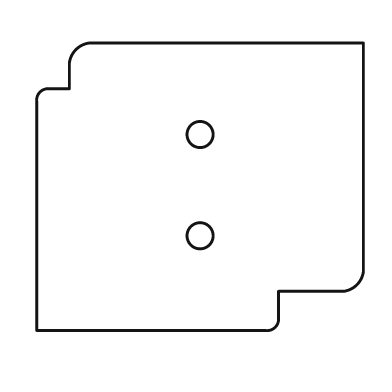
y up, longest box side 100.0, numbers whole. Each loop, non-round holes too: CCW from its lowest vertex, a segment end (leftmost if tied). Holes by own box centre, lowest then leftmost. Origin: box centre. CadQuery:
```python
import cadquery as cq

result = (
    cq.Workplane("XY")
    .moveTo(-50.0, -44.0)
    .lineTo(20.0, -44.0)
    .threePointArc((23.0, -43.0), (24.0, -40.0))
    .lineTo(24.0, -32.0)
    .lineTo(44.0, -32.0)
    .threePointArc((48.0, -30.0), (50.0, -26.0))
    .lineTo(50.0, 44.0)
    .lineTo(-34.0, 44.0)
    .threePointArc((-38.0, 42.0), (-40.0, 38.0))
    .lineTo(-40.0, 30.0)
    .lineTo(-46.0, 30.0)
    .threePointArc((-49.0, 29.0), (-50.0, 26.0))
    .close()
    .moveTo(0.0, -15.0)
    .circle(4.0)
    .moveTo(0.0, 16.0)
    .circle(4.0)
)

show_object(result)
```